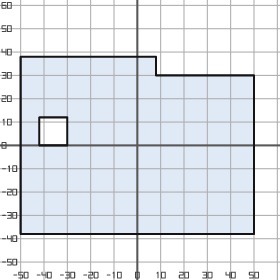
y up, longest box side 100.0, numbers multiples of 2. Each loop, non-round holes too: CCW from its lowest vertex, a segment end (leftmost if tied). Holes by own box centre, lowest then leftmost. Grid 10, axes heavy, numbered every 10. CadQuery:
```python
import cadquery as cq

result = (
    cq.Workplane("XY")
    .moveTo(-50.0, -38.0)
    .lineTo(50.0, -38.0)
    .lineTo(50.0, 30.0)
    .lineTo(8.0, 30.0)
    .lineTo(8.0, 38.0)
    .lineTo(-50.0, 38.0)
    .close()
    .moveTo(-42.0, 0.0)
    .lineTo(-30.0, 0.0)
    .lineTo(-30.0, 12.0)
    .lineTo(-42.0, 12.0)
    .close()
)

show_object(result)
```